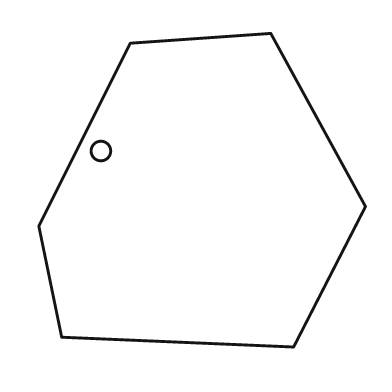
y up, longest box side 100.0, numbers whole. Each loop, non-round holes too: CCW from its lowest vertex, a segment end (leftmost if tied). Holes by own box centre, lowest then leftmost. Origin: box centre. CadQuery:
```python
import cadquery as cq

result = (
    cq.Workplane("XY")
    .moveTo(28.0, -48.0)
    .lineTo(50.0, -5.0)
    .lineTo(21.0, 48.0)
    .lineTo(-22.0, 45.0)
    .lineTo(-50.0, -11.0)
    .lineTo(-43.0, -45.0)
    .close()
    .moveTo(-31.0, 12.0)
    .circle(3.0)
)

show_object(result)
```